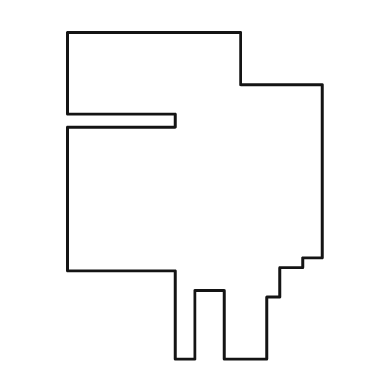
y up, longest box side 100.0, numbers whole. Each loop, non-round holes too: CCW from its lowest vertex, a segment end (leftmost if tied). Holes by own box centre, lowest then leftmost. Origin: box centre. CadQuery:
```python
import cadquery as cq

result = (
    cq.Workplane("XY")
    .moveTo(-6.0, -50.0)
    .lineTo(0.0, -50.0)
    .lineTo(0.0, -29.0)
    .lineTo(9.0, -29.0)
    .lineTo(9.0, -50.0)
    .lineTo(22.0, -50.0)
    .lineTo(22.0, -31.0)
    .lineTo(26.0, -31.0)
    .lineTo(26.0, -22.0)
    .lineTo(33.0, -22.0)
    .lineTo(33.0, -19.0)
    .lineTo(39.0, -19.0)
    .lineTo(39.0, 34.0)
    .lineTo(14.0, 34.0)
    .lineTo(14.0, 50.0)
    .lineTo(-39.0, 50.0)
    .lineTo(-39.0, 25.0)
    .lineTo(-6.0, 25.0)
    .lineTo(-6.0, 21.0)
    .lineTo(-39.0, 21.0)
    .lineTo(-39.0, -23.0)
    .lineTo(-6.0, -23.0)
    .close()
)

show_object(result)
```